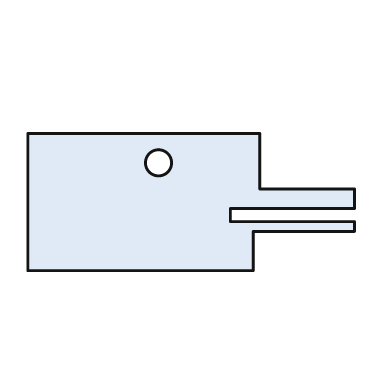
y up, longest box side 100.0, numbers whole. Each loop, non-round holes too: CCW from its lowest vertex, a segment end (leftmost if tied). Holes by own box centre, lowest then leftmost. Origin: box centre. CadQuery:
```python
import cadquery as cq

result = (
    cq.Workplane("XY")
    .moveTo(-50.0, -21.0)
    .lineTo(19.0, -21.0)
    .lineTo(19.0, -9.0)
    .lineTo(50.0, -9.0)
    .lineTo(50.0, -6.0)
    .lineTo(12.0, -6.0)
    .lineTo(12.0, -2.0)
    .lineTo(50.0, -2.0)
    .lineTo(50.0, 4.0)
    .lineTo(21.0, 4.0)
    .lineTo(21.0, 21.0)
    .lineTo(-50.0, 21.0)
    .close()
    .moveTo(-10.0, 12.0)
    .circle(4.0)
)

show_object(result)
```